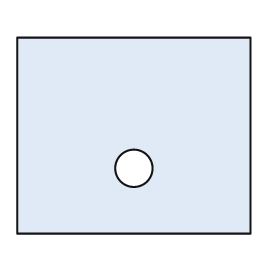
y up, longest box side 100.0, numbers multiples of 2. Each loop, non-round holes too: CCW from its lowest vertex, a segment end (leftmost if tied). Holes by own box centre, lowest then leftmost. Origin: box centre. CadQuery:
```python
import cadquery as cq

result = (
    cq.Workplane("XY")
    .moveTo(-50.0, -42.0)
    .lineTo(50.0, -42.0)
    .lineTo(50.0, 42.0)
    .lineTo(-50.0, 42.0)
    .close()
    .moveTo(0.0, -14.0)
    .circle(8.0)
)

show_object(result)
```